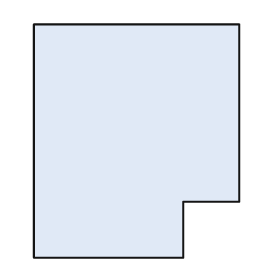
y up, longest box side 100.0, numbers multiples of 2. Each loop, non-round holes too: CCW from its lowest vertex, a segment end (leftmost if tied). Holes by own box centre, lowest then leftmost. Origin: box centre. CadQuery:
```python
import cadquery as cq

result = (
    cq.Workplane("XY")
    .moveTo(-44.0, -50.0)
    .lineTo(20.0, -50.0)
    .lineTo(20.0, -26.0)
    .lineTo(44.0, -26.0)
    .lineTo(44.0, 50.0)
    .lineTo(-44.0, 50.0)
    .close()
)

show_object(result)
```